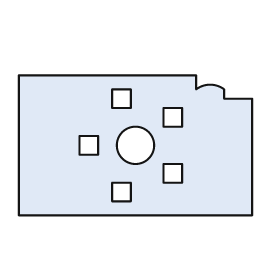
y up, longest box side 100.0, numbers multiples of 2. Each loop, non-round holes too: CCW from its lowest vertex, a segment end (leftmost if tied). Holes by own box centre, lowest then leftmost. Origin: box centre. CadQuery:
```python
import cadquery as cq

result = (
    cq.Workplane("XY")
    .moveTo(-50.0, -30.0)
    .lineTo(50.0, -30.0)
    .lineTo(50.0, 20.0)
    .lineTo(38.0, 20.0)
    .lineTo(38.0, 24.0)
    .threePointArc((32.0, 26.0), (26.0, 24.0))
    .lineTo(26.0, 30.0)
    .lineTo(-50.0, 30.0)
    .close()
    .moveTo(-10.0, -24.0)
    .lineTo(-2.0, -24.0)
    .lineTo(-2.0, -16.0)
    .lineTo(-10.0, -16.0)
    .close()
    .moveTo(12.0, -16.0)
    .lineTo(20.0, -16.0)
    .lineTo(20.0, -8.0)
    .lineTo(12.0, -8.0)
    .close()
    .moveTo(-24.0, -4.0)
    .lineTo(-16.0, -4.0)
    .lineTo(-16.0, 4.0)
    .lineTo(-24.0, 4.0)
    .close()
    .moveTo(0.0, 0.0)
    .circle(8.0)
    .moveTo(12.0, 8.0)
    .lineTo(20.0, 8.0)
    .lineTo(20.0, 16.0)
    .lineTo(12.0, 16.0)
    .close()
    .moveTo(-10.0, 16.0)
    .lineTo(-2.0, 16.0)
    .lineTo(-2.0, 24.0)
    .lineTo(-10.0, 24.0)
    .close()
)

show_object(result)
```